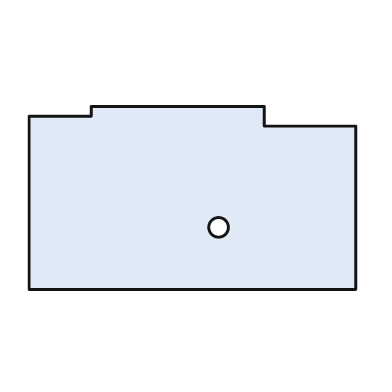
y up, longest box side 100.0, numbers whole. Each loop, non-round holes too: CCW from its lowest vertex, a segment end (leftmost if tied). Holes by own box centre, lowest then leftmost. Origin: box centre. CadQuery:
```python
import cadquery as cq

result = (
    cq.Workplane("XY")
    .moveTo(-50.0, -28.0)
    .lineTo(50.0, -28.0)
    .lineTo(50.0, 22.0)
    .lineTo(22.0, 22.0)
    .lineTo(22.0, 28.0)
    .lineTo(-31.0, 28.0)
    .lineTo(-31.0, 25.0)
    .lineTo(-50.0, 25.0)
    .close()
    .moveTo(8.0, -9.0)
    .circle(3.0)
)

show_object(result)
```